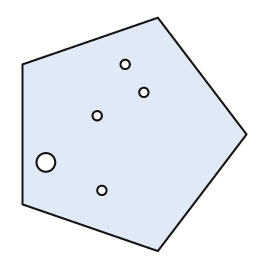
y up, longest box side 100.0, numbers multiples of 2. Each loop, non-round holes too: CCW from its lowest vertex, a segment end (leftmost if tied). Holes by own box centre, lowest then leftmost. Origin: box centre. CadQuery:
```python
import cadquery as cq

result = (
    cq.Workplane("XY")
    .moveTo(10.0, -50.0)
    .lineTo(48.0, 0.0)
    .lineTo(10.0, 50.0)
    .lineTo(-48.0, 30.0)
    .lineTo(-48.0, -30.0)
    .close()
    .moveTo(-14.0, -24.0)
    .circle(2.0)
    .moveTo(-38.0, -12.0)
    .circle(4.0)
    .moveTo(-16.0, 8.0)
    .circle(2.0)
    .moveTo(4.0, 18.0)
    .circle(2.0)
    .moveTo(-4.0, 30.0)
    .circle(2.0)
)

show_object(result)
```